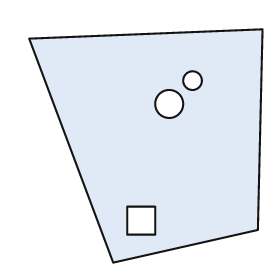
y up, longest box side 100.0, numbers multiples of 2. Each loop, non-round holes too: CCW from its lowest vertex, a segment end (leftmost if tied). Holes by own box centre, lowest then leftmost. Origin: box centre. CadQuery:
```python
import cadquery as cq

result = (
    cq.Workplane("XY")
    .moveTo(-14.0, -50.0)
    .lineTo(48.0, -36.0)
    .lineTo(50.0, 50.0)
    .lineTo(-50.0, 46.0)
    .close()
    .moveTo(-8.0, -38.0)
    .lineTo(4.0, -38.0)
    .lineTo(4.0, -26.0)
    .lineTo(-8.0, -26.0)
    .close()
    .moveTo(10.0, 18.0)
    .circle(6.0)
    .moveTo(20.0, 28.0)
    .circle(4.0)
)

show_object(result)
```